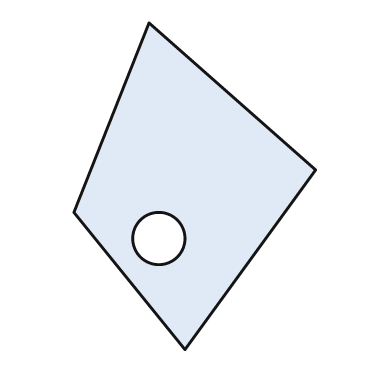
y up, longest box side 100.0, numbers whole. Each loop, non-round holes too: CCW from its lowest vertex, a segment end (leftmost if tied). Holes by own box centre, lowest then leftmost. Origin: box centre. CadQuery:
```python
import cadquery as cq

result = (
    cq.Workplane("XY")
    .moveTo(-3.0, -50.0)
    .lineTo(37.0, 5.0)
    .lineTo(-14.0, 50.0)
    .lineTo(-37.0, -8.0)
    .close()
    .moveTo(-11.0, -16.0)
    .circle(8.0)
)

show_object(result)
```